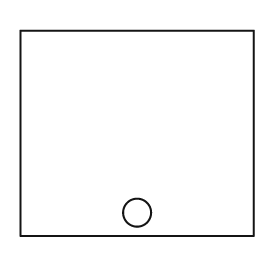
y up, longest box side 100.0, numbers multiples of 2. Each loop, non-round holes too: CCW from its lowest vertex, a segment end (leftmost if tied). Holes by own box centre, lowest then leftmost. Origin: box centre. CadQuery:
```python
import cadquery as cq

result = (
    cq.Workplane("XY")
    .moveTo(-50.0, -44.0)
    .lineTo(50.0, -44.0)
    .lineTo(50.0, 44.0)
    .lineTo(-50.0, 44.0)
    .close()
    .moveTo(0.0, -34.0)
    .circle(6.0)
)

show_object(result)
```